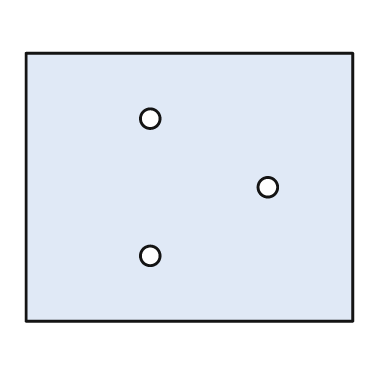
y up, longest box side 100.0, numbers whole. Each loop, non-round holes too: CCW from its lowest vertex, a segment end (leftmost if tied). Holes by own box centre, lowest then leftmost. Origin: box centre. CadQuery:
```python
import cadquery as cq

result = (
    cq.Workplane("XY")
    .moveTo(-50.0, -41.0)
    .lineTo(50.0, -41.0)
    .lineTo(50.0, 41.0)
    .lineTo(-50.0, 41.0)
    .close()
    .moveTo(-12.0, -21.0)
    .circle(3.0)
    .moveTo(24.0, 0.0)
    .circle(3.0)
    .moveTo(-12.0, 21.0)
    .circle(3.0)
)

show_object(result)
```